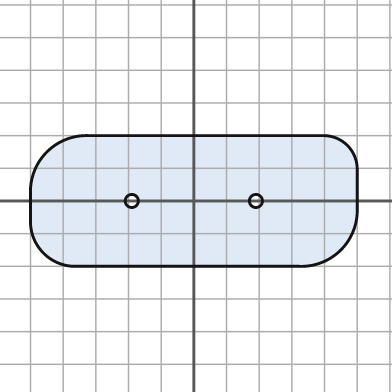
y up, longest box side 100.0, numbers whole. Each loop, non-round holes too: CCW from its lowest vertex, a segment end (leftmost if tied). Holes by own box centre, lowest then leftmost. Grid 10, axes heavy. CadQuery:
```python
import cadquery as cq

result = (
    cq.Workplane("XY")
    .moveTo(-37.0, -20.0)
    .lineTo(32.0, -20.0)
    .threePointArc((45.0, -15.0), (50.0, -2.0))
    .lineTo(50.0, 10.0)
    .threePointArc((47.0, 17.0), (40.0, 20.0))
    .lineTo(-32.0, 20.0)
    .threePointArc((-45.0, 15.0), (-50.0, 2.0))
    .lineTo(-50.0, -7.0)
    .threePointArc((-46.0, -16.0), (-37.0, -20.0))
    .close()
    .moveTo(-19.0, 0.0)
    .circle(2.0)
    .moveTo(19.0, 0.0)
    .circle(2.0)
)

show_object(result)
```